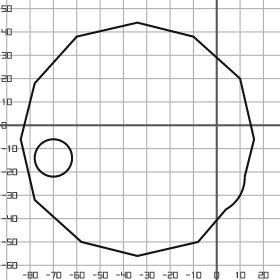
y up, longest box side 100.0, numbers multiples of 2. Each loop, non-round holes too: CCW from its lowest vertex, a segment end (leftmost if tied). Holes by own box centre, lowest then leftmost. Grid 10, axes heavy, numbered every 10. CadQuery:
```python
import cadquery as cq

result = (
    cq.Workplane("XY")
    .moveTo(-34.0, -56.0)
    .lineTo(-8.0, -50.0)
    .lineTo(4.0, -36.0)
    .threePointArc((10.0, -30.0), (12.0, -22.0))
    .lineTo(16.0, -6.0)
    .lineTo(10.0, 20.0)
    .lineTo(-10.0, 38.0)
    .lineTo(-34.0, 44.0)
    .lineTo(-60.0, 38.0)
    .lineTo(-78.0, 18.0)
    .lineTo(-84.0, -6.0)
    .lineTo(-78.0, -32.0)
    .lineTo(-58.0, -50.0)
    .close()
    .moveTo(-70.0, -14.0)
    .circle(8.0)
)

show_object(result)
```